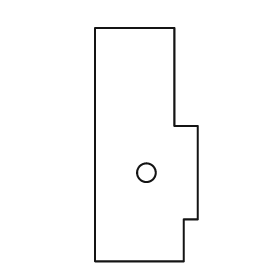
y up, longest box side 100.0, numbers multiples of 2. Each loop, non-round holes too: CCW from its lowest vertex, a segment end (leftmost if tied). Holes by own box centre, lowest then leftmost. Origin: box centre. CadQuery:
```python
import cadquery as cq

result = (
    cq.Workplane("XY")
    .moveTo(-22.0, -50.0)
    .lineTo(16.0, -50.0)
    .lineTo(16.0, -32.0)
    .lineTo(22.0, -32.0)
    .lineTo(22.0, 8.0)
    .lineTo(12.0, 8.0)
    .lineTo(12.0, 50.0)
    .lineTo(-22.0, 50.0)
    .close()
    .moveTo(0.0, -12.0)
    .circle(4.0)
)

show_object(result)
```